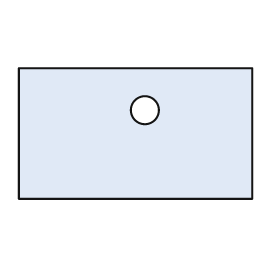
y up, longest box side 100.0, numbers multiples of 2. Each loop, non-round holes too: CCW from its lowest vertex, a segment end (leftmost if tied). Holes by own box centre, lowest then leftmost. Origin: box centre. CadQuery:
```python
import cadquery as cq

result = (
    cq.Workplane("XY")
    .moveTo(-50.0, -28.0)
    .lineTo(50.0, -28.0)
    .lineTo(50.0, 28.0)
    .lineTo(-50.0, 28.0)
    .close()
    .moveTo(4.0, 10.0)
    .circle(6.0)
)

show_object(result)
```